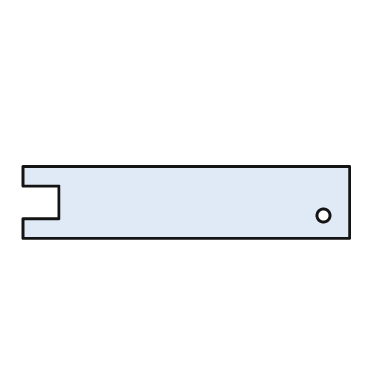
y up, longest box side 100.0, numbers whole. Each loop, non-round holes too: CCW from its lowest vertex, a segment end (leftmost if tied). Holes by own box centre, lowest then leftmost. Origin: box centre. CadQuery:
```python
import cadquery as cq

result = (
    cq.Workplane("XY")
    .moveTo(-50.0, -11.0)
    .lineTo(50.0, -11.0)
    .lineTo(50.0, 11.0)
    .lineTo(-50.0, 11.0)
    .lineTo(-50.0, 5.0)
    .lineTo(-39.0, 5.0)
    .lineTo(-39.0, -5.0)
    .lineTo(-50.0, -5.0)
    .close()
    .moveTo(42.0, -4.0)
    .circle(2.0)
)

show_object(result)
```